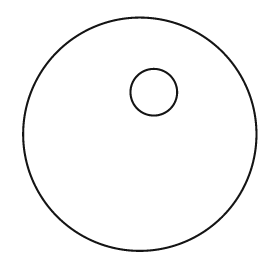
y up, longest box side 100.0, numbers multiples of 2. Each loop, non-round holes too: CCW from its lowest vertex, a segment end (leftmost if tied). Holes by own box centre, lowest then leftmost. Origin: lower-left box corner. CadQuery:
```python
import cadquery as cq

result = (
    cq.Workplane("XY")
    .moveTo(50.0, 50.0)
    .circle(50.0)
    .moveTo(56.0, 68.0)
    .circle(10.0)
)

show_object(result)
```